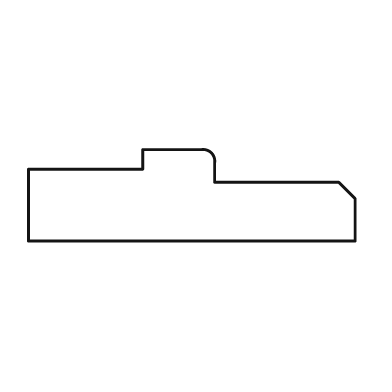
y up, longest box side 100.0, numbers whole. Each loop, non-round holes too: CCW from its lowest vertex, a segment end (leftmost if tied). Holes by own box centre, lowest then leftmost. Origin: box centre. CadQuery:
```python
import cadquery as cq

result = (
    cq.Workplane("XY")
    .moveTo(-50.0, -14.0)
    .lineTo(50.0, -14.0)
    .lineTo(50.0, -1.0)
    .lineTo(45.0, 4.0)
    .lineTo(7.0, 4.0)
    .lineTo(7.0, 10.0)
    .threePointArc((6.0, 13.0), (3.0, 14.0))
    .lineTo(-15.0, 14.0)
    .lineTo(-15.0, 8.0)
    .lineTo(-50.0, 8.0)
    .close()
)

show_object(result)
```